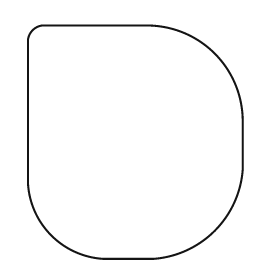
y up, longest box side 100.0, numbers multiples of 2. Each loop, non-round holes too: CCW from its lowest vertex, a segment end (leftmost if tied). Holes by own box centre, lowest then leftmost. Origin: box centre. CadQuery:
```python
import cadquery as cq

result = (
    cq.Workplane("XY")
    .moveTo(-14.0, -50.0)
    .lineTo(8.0, -50.0)
    .threePointArc((34.0, -38.0), (46.0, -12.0))
    .lineTo(46.0, 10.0)
    .threePointArc((34.0, 38.0), (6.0, 50.0))
    .lineTo(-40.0, 50.0)
    .threePointArc((-44.0, 48.0), (-46.0, 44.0))
    .lineTo(-46.0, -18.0)
    .threePointArc((-36.0, -40.0), (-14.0, -50.0))
    .close()
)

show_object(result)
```